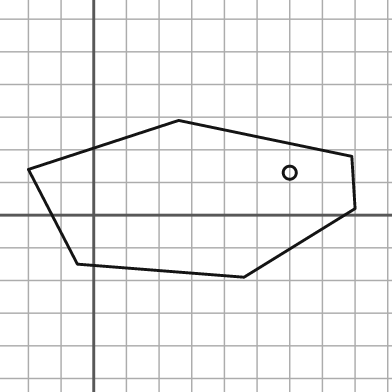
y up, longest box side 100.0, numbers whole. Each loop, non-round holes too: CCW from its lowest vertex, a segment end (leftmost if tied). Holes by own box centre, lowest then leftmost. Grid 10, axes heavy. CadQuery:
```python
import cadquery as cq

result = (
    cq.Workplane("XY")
    .moveTo(46.0, -19.0)
    .lineTo(80.0, 2.0)
    .lineTo(79.0, 18.0)
    .lineTo(26.0, 29.0)
    .lineTo(-20.0, 14.0)
    .lineTo(-5.0, -15.0)
    .close()
    .moveTo(60.0, 13.0)
    .circle(2.0)
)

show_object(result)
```